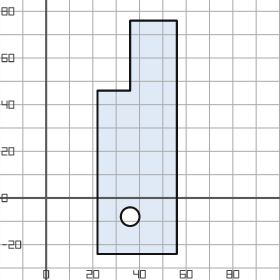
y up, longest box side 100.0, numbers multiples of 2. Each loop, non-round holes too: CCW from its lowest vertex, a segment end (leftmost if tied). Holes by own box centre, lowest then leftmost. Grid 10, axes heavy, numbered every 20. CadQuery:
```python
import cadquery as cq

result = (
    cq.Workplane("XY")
    .moveTo(22.0, -24.0)
    .lineTo(56.0, -24.0)
    .lineTo(56.0, 76.0)
    .lineTo(36.0, 76.0)
    .lineTo(36.0, 46.0)
    .lineTo(22.0, 46.0)
    .close()
    .moveTo(36.0, -8.0)
    .circle(4.0)
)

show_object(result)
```